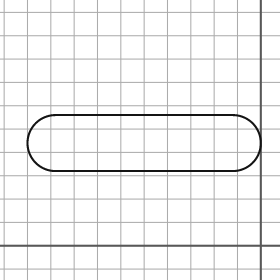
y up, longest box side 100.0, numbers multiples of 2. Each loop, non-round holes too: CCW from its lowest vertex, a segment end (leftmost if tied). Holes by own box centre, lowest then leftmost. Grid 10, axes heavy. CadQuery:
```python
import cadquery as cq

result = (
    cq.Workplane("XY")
    .moveTo(-88.0, 32.0)
    .lineTo(-12.0, 32.0)
    .threePointArc((0.0, 44.0), (-12.0, 56.0))
    .lineTo(-88.0, 56.0)
    .threePointArc((-100.0, 44.0), (-88.0, 32.0))
    .close()
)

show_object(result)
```